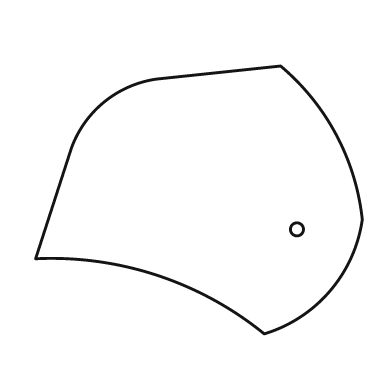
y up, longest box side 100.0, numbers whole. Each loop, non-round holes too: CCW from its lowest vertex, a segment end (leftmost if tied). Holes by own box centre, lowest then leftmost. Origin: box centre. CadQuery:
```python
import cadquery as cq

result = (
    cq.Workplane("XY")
    .moveTo(20.0, -41.0)
    .threePointArc((40.0, -28.0), (50.0, -6.0))
    .threePointArc((42.0, 20.0), (25.0, 41.0))
    .lineTo(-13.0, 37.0)
    .threePointArc((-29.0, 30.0), (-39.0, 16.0))
    .lineTo(-50.0, -18.0)
    .threePointArc((-13.0, -23.0), (20.0, -41.0))
    .close()
    .moveTo(30.0, -9.0)
    .circle(2.0)
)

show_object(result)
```